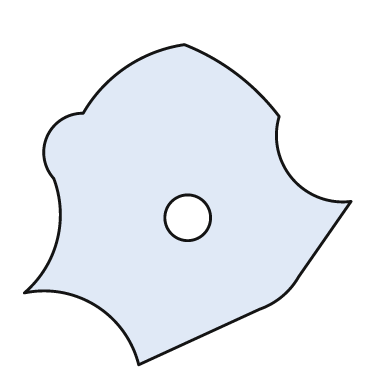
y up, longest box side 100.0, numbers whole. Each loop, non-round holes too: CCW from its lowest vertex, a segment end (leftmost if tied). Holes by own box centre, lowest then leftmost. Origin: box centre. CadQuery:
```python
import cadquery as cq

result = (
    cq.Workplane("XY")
    .moveTo(-15.0, -49.0)
    .lineTo(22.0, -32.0)
    .threePointArc((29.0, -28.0), (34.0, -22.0))
    .lineTo(50.0, 1.0)
    .threePointArc((32.0, 8.0), (28.0, 27.0))
    .threePointArc((15.0, 40.0), (-1.0, 49.0))
    .threePointArc((-19.0, 42.0), (-32.0, 28.0))
    .threePointArc((-43.0, 21.0), (-41.0, 8.0))
    .threePointArc((-40.0, -11.0), (-50.0, -27.0))
    .threePointArc((-28.0, -31.0), (-15.0, -49.0))
    .close()
    .moveTo(0.0, -4.0)
    .circle(7.0)
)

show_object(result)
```